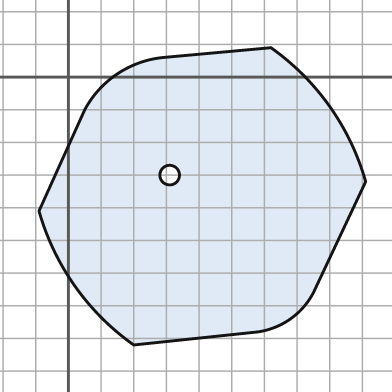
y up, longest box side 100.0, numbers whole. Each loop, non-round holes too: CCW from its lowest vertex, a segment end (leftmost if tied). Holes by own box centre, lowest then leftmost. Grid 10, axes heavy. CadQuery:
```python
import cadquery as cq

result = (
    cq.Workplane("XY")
    .moveTo(20.0, -82.0)
    .lineTo(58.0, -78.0)
    .threePointArc((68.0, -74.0), (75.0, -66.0))
    .lineTo(91.0, -32.0)
    .threePointArc((80.0, -9.0), (62.0, 9.0))
    .lineTo(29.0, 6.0)
    .threePointArc((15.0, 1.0), (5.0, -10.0))
    .lineTo(-9.0, -41.0)
    .threePointArc((2.0, -64.0), (20.0, -82.0))
    .close()
    .moveTo(31.0, -30.0)
    .circle(3.0)
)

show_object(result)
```